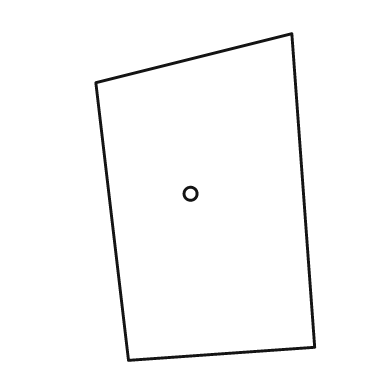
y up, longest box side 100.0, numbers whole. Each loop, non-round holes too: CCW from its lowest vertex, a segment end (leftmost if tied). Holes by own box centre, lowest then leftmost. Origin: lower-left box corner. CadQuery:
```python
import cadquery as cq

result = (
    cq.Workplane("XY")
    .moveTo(10.0, 0.0)
    .lineTo(67.0, 4.0)
    .lineTo(60.0, 100.0)
    .lineTo(0.0, 85.0)
    .close()
    .moveTo(29.0, 51.0)
    .circle(2.0)
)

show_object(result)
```